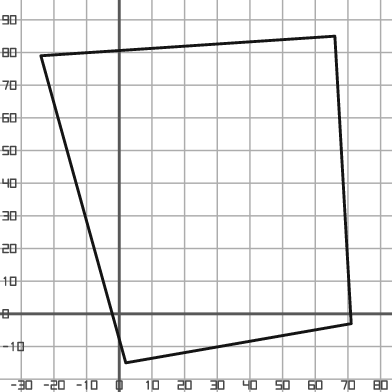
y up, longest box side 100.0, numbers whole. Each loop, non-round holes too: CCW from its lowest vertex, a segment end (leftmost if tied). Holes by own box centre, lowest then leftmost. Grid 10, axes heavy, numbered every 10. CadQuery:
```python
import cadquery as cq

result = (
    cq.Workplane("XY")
    .moveTo(2.0, -15.0)
    .lineTo(71.0, -3.0)
    .lineTo(66.0, 85.0)
    .lineTo(-24.0, 79.0)
    .close()
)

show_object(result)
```